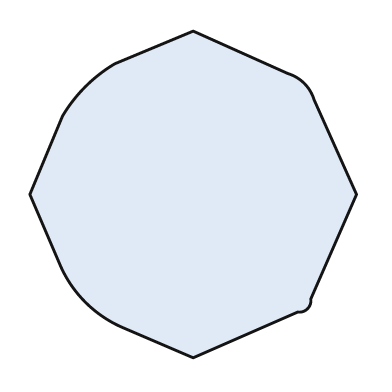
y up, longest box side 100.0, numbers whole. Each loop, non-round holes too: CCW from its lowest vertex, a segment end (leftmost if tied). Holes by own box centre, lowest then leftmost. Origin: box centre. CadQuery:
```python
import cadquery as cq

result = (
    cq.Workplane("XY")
    .moveTo(0.0, -50.0)
    .lineTo(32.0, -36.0)
    .threePointArc((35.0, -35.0), (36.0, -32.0))
    .lineTo(50.0, 0.0)
    .lineTo(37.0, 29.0)
    .threePointArc((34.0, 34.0), (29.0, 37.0))
    .lineTo(0.0, 50.0)
    .lineTo(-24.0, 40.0)
    .threePointArc((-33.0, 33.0), (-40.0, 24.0))
    .lineTo(-50.0, 0.0)
    .lineTo(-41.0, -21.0)
    .threePointArc((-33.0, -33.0), (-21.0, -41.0))
    .close()
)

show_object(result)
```